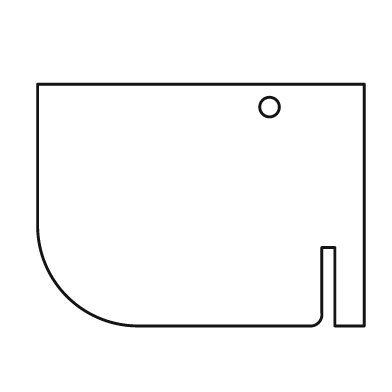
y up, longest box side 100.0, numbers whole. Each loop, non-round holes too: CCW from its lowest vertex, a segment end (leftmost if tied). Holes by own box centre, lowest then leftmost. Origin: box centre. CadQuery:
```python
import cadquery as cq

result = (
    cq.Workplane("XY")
    .moveTo(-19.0, -37.0)
    .lineTo(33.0, -37.0)
    .threePointArc((36.0, -36.0), (37.0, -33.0))
    .lineTo(37.0, -13.0)
    .lineTo(41.0, -13.0)
    .lineTo(41.0, -37.0)
    .lineTo(50.0, -37.0)
    .lineTo(50.0, 37.0)
    .lineTo(-50.0, 37.0)
    .lineTo(-50.0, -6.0)
    .threePointArc((-41.0, -28.0), (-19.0, -37.0))
    .close()
    .moveTo(21.0, 30.0)
    .circle(3.0)
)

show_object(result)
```